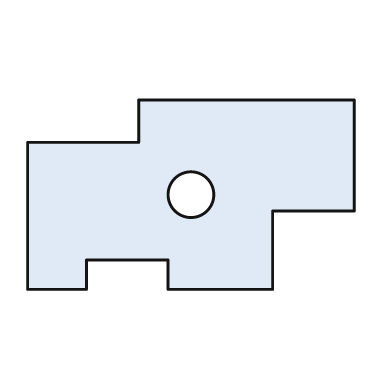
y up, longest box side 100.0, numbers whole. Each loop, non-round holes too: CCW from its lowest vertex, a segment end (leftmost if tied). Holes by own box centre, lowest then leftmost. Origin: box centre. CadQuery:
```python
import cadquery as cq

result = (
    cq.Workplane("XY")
    .moveTo(-50.0, -29.0)
    .lineTo(-32.0, -29.0)
    .lineTo(-32.0, -20.0)
    .lineTo(-7.0, -20.0)
    .lineTo(-7.0, -29.0)
    .lineTo(25.0, -29.0)
    .lineTo(25.0, -5.0)
    .lineTo(50.0, -5.0)
    .lineTo(50.0, 29.0)
    .lineTo(-16.0, 29.0)
    .lineTo(-16.0, 16.0)
    .lineTo(-50.0, 16.0)
    .close()
    .moveTo(0.0, 0.0)
    .circle(7.0)
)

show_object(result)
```